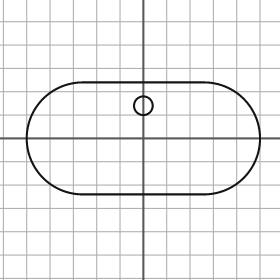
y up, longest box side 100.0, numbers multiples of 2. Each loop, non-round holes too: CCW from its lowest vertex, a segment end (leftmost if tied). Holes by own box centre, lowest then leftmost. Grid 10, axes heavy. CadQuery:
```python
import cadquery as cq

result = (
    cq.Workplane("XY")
    .moveTo(-26.0, -24.0)
    .lineTo(26.0, -24.0)
    .threePointArc((50.0, 0.0), (26.0, 24.0))
    .lineTo(-26.0, 24.0)
    .threePointArc((-50.0, 0.0), (-26.0, -24.0))
    .close()
    .moveTo(0.0, 14.0)
    .circle(4.0)
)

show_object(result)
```